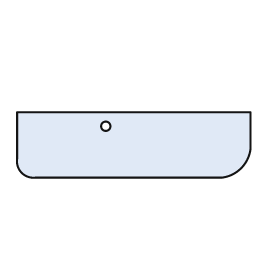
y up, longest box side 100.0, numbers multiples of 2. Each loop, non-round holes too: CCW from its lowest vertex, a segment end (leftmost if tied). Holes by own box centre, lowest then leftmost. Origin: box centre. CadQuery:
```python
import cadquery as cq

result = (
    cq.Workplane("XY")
    .moveTo(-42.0, -14.0)
    .lineTo(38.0, -14.0)
    .threePointArc((46.0, -10.0), (50.0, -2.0))
    .lineTo(50.0, 14.0)
    .lineTo(-50.0, 14.0)
    .lineTo(-50.0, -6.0)
    .threePointArc((-48.0, -12.0), (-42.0, -14.0))
    .close()
    .moveTo(-12.0, 8.0)
    .circle(2.0)
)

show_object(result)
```